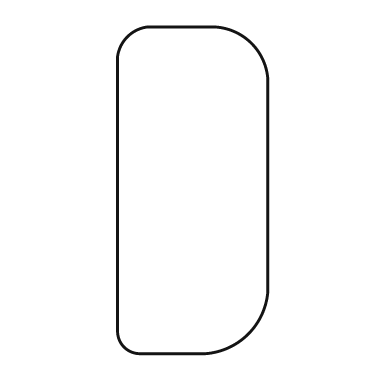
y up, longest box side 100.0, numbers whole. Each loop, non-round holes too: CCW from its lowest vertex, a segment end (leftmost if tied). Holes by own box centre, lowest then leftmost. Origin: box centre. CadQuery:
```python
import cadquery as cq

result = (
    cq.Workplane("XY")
    .moveTo(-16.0, -50.0)
    .lineTo(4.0, -50.0)
    .threePointArc((17.0, -44.0), (23.0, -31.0))
    .lineTo(23.0, 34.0)
    .threePointArc((18.0, 45.0), (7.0, 50.0))
    .lineTo(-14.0, 50.0)
    .threePointArc((-20.0, 47.0), (-23.0, 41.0))
    .lineTo(-23.0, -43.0)
    .threePointArc((-21.0, -48.0), (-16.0, -50.0))
    .close()
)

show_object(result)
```